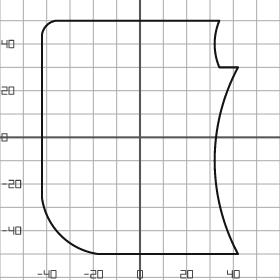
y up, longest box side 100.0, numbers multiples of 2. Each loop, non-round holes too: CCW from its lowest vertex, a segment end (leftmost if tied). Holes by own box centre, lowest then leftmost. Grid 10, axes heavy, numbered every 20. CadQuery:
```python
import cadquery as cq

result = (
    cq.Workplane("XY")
    .moveTo(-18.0, -50.0)
    .lineTo(42.0, -50.0)
    .threePointArc((32.0, -10.0), (42.0, 30.0))
    .lineTo(34.0, 30.0)
    .threePointArc((32.0, 40.0), (34.0, 50.0))
    .lineTo(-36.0, 50.0)
    .threePointArc((-40.0, 48.0), (-42.0, 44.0))
    .lineTo(-42.0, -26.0)
    .threePointArc((-34.0, -42.0), (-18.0, -50.0))
    .close()
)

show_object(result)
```